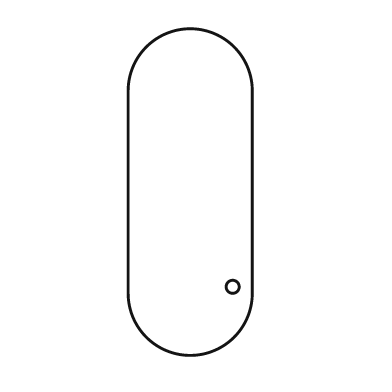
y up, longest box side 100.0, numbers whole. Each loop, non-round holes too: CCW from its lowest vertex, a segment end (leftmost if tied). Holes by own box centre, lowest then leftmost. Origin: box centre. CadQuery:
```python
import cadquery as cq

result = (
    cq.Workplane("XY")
    .moveTo(-19.0, -31.0)
    .threePointArc((0.0, -50.0), (19.0, -31.0))
    .lineTo(19.0, 31.0)
    .threePointArc((0.0, 50.0), (-19.0, 31.0))
    .close()
    .moveTo(13.0, -29.0)
    .circle(2.0)
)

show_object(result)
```